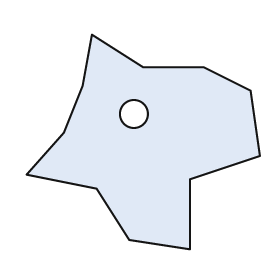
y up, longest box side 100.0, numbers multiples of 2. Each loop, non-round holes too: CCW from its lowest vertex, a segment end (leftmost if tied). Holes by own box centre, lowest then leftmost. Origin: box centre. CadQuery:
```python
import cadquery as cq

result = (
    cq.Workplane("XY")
    .moveTo(20.0, -46.0)
    .lineTo(20.0, -16.0)
    .lineTo(50.0, -6.0)
    .lineTo(46.0, 22.0)
    .lineTo(26.0, 32.0)
    .lineTo(0.0, 32.0)
    .lineTo(-22.0, 46.0)
    .lineTo(-26.0, 24.0)
    .lineTo(-34.0, 4.0)
    .lineTo(-50.0, -14.0)
    .lineTo(-20.0, -20.0)
    .lineTo(-6.0, -42.0)
    .close()
    .moveTo(-4.0, 12.0)
    .circle(6.0)
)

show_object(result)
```